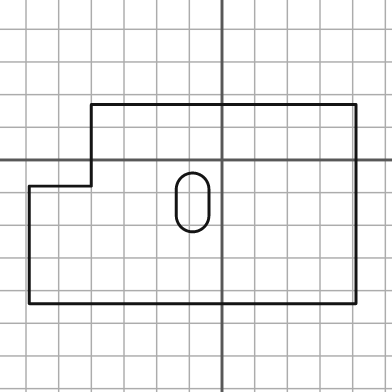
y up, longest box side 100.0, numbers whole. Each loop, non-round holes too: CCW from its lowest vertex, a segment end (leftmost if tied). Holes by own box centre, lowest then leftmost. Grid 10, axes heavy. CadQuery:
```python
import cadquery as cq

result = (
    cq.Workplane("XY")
    .moveTo(-59.0, -44.0)
    .lineTo(41.0, -44.0)
    .lineTo(41.0, 17.0)
    .lineTo(-40.0, 17.0)
    .lineTo(-40.0, -8.0)
    .lineTo(-59.0, -8.0)
    .close()
    .moveTo(-14.0, -17.0)
    .threePointArc((-9.0, -22.0), (-4.0, -17.0))
    .lineTo(-4.0, -9.0)
    .threePointArc((-9.0, -4.0), (-14.0, -9.0))
    .close()
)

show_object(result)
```